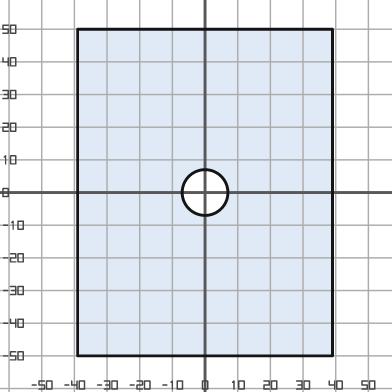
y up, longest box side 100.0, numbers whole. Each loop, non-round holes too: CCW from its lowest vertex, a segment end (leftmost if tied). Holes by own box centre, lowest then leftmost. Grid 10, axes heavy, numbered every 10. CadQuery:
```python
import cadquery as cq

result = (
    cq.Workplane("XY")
    .moveTo(-39.0, -50.0)
    .lineTo(39.0, -50.0)
    .lineTo(39.0, 50.0)
    .lineTo(-39.0, 50.0)
    .close()
    .moveTo(0.0, 0.0)
    .circle(7.0)
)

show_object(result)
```